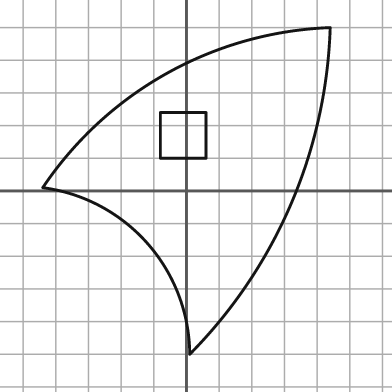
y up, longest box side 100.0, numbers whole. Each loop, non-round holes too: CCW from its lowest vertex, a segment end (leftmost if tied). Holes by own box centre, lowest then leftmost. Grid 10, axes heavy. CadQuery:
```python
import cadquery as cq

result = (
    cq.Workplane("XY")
    .moveTo(1.0, -50.0)
    .threePointArc((32.0, -4.0), (44.0, 50.0))
    .threePointArc((-6.0, 36.0), (-44.0, 1.0))
    .threePointArc((-12.0, -16.0), (1.0, -50.0))
    .close()
    .moveTo(-8.0, 10.0)
    .lineTo(6.0, 10.0)
    .lineTo(6.0, 24.0)
    .lineTo(-8.0, 24.0)
    .close()
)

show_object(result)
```